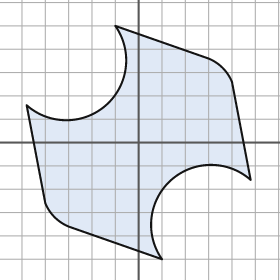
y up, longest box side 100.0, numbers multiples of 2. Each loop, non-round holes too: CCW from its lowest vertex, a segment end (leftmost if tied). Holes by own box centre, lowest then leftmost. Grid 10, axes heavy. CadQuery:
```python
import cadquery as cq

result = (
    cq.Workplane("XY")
    .moveTo(10.0, -50.0)
    .threePointArc((14.0, -16.0), (48.0, -16.0))
    .lineTo(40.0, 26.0)
    .threePointArc((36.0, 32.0), (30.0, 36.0))
    .lineTo(-10.0, 50.0)
    .threePointArc((-14.0, 16.0), (-48.0, 16.0))
    .lineTo(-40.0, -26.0)
    .threePointArc((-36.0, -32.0), (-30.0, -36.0))
    .close()
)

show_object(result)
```